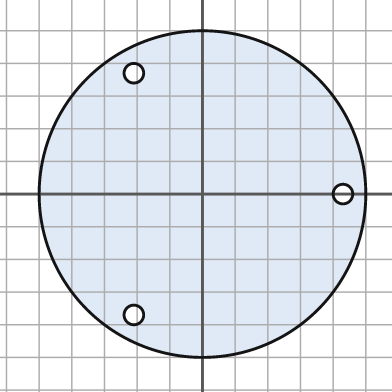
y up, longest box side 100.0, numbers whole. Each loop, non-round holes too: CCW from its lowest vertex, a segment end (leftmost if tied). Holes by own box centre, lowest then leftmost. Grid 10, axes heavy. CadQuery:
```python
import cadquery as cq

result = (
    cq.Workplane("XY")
    .moveTo(0.0, 0.0)
    .circle(50.0)
    .moveTo(-21.0, -37.0)
    .circle(3.0)
    .moveTo(43.0, 0.0)
    .circle(3.0)
    .moveTo(-21.0, 37.0)
    .circle(3.0)
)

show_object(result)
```